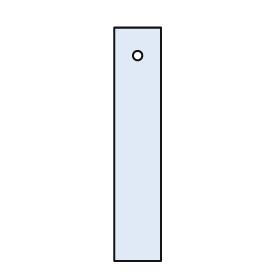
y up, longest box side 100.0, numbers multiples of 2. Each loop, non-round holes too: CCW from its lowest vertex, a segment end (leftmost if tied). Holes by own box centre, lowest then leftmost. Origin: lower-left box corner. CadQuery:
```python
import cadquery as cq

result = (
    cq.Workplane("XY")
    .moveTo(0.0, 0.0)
    .lineTo(20.0, 0.0)
    .lineTo(20.0, 100.0)
    .lineTo(0.0, 100.0)
    .close()
    .moveTo(10.0, 88.0)
    .circle(2.0)
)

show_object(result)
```